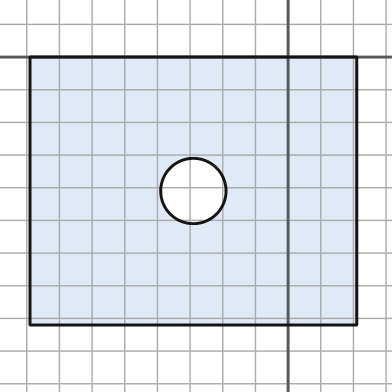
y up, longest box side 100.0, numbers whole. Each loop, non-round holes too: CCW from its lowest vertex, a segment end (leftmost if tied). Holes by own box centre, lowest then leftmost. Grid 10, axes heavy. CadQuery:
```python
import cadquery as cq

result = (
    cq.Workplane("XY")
    .moveTo(-79.0, -82.0)
    .lineTo(21.0, -82.0)
    .lineTo(21.0, 0.0)
    .lineTo(-79.0, 0.0)
    .close()
    .moveTo(-29.0, -41.0)
    .circle(10.0)
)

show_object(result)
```